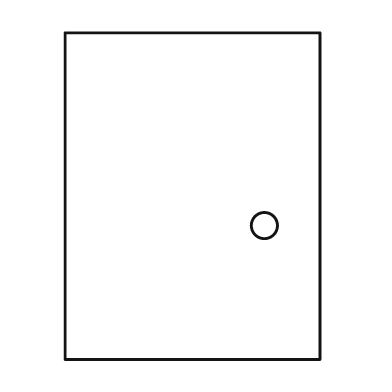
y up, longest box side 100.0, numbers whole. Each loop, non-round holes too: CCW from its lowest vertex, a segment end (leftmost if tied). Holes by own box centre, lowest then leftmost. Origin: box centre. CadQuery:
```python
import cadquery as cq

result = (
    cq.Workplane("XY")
    .moveTo(-39.0, -50.0)
    .lineTo(39.0, -50.0)
    .lineTo(39.0, 50.0)
    .lineTo(-39.0, 50.0)
    .close()
    .moveTo(22.0, -9.0)
    .circle(4.0)
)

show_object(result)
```